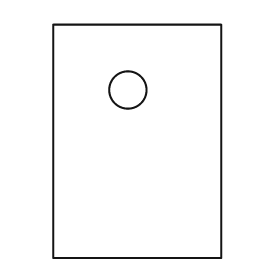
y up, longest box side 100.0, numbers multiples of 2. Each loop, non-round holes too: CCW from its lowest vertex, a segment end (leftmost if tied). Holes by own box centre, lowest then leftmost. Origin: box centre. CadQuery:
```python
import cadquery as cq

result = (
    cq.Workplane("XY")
    .moveTo(-36.0, -50.0)
    .lineTo(36.0, -50.0)
    .lineTo(36.0, 50.0)
    .lineTo(-36.0, 50.0)
    .close()
    .moveTo(-4.0, 22.0)
    .circle(8.0)
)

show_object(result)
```